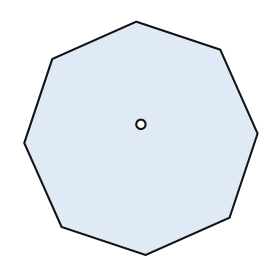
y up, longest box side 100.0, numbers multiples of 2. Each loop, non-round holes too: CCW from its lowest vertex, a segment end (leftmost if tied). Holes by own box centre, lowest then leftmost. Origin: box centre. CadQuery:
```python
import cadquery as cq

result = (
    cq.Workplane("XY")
    .moveTo(2.0, -50.0)
    .lineTo(38.0, -34.0)
    .lineTo(50.0, 2.0)
    .lineTo(34.0, 38.0)
    .lineTo(-2.0, 50.0)
    .lineTo(-38.0, 34.0)
    .lineTo(-50.0, -2.0)
    .lineTo(-34.0, -38.0)
    .close()
    .moveTo(0.0, 6.0)
    .circle(2.0)
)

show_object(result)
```